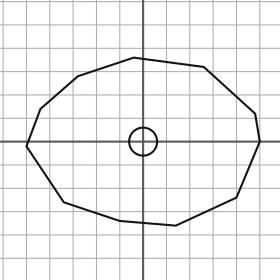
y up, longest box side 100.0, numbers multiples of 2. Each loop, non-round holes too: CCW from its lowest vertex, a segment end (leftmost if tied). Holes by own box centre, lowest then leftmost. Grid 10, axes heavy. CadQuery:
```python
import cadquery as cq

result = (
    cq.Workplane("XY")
    .moveTo(14.0, -36.0)
    .lineTo(40.0, -24.0)
    .lineTo(50.0, 0.0)
    .lineTo(48.0, 12.0)
    .lineTo(26.0, 32.0)
    .lineTo(-4.0, 36.0)
    .lineTo(-28.0, 28.0)
    .lineTo(-44.0, 14.0)
    .lineTo(-50.0, -2.0)
    .lineTo(-34.0, -26.0)
    .lineTo(-10.0, -34.0)
    .close()
    .moveTo(0.0, 0.0)
    .circle(6.0)
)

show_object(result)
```